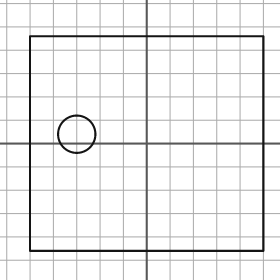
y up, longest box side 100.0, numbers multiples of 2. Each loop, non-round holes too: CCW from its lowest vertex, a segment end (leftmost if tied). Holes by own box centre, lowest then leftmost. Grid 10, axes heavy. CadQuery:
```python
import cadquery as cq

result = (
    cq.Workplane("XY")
    .moveTo(-50.0, -46.0)
    .lineTo(50.0, -46.0)
    .lineTo(50.0, 46.0)
    .lineTo(-50.0, 46.0)
    .close()
    .moveTo(-30.0, 4.0)
    .circle(8.0)
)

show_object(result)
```